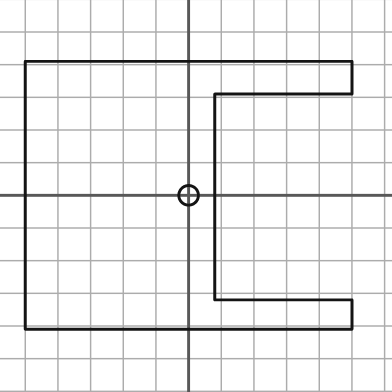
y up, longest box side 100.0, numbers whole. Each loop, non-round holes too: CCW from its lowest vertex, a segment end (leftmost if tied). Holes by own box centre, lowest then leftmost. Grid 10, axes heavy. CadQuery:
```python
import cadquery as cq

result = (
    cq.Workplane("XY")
    .moveTo(-50.0, -41.0)
    .lineTo(50.0, -41.0)
    .lineTo(50.0, -32.0)
    .lineTo(8.0, -32.0)
    .lineTo(8.0, 31.0)
    .lineTo(50.0, 31.0)
    .lineTo(50.0, 41.0)
    .lineTo(-50.0, 41.0)
    .close()
    .moveTo(0.0, 0.0)
    .circle(3.0)
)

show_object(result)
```